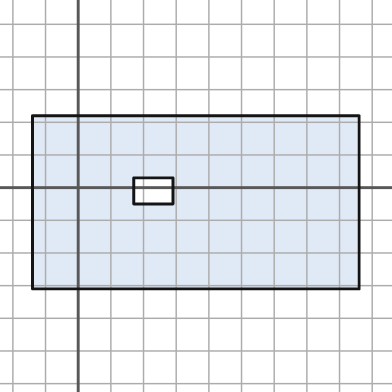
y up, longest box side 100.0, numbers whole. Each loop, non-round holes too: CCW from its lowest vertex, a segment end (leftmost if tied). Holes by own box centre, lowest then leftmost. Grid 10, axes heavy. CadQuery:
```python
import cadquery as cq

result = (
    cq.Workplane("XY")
    .moveTo(-14.0, -31.0)
    .lineTo(86.0, -31.0)
    .lineTo(86.0, 22.0)
    .lineTo(-14.0, 22.0)
    .close()
    .moveTo(17.0, -5.0)
    .lineTo(29.0, -5.0)
    .lineTo(29.0, 3.0)
    .lineTo(17.0, 3.0)
    .close()
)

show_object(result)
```